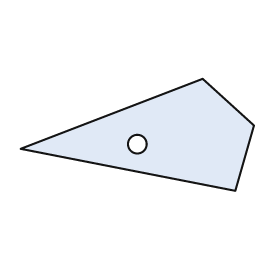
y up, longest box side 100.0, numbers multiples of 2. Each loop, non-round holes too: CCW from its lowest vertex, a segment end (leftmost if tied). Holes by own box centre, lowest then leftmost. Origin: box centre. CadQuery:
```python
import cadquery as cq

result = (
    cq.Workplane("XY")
    .moveTo(42.0, -24.0)
    .lineTo(50.0, 4.0)
    .lineTo(28.0, 24.0)
    .lineTo(-50.0, -6.0)
    .close()
    .moveTo(0.0, -4.0)
    .circle(4.0)
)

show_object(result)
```